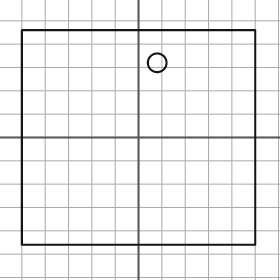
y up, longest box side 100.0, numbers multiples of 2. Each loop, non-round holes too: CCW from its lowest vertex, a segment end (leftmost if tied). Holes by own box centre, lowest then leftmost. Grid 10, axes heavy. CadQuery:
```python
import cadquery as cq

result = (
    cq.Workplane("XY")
    .moveTo(-50.0, -46.0)
    .lineTo(50.0, -46.0)
    .lineTo(50.0, 46.0)
    .lineTo(-50.0, 46.0)
    .close()
    .moveTo(8.0, 32.0)
    .circle(4.0)
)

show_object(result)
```